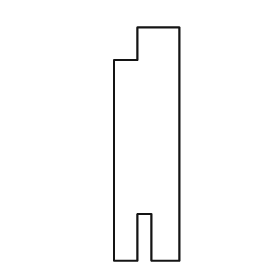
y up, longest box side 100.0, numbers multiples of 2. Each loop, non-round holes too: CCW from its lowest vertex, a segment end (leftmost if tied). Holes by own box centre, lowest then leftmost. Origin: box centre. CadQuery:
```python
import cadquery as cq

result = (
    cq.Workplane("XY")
    .moveTo(-14.0, -50.0)
    .lineTo(-4.0, -50.0)
    .lineTo(-4.0, -30.0)
    .lineTo(2.0, -30.0)
    .lineTo(2.0, -50.0)
    .lineTo(14.0, -50.0)
    .lineTo(14.0, 50.0)
    .lineTo(-4.0, 50.0)
    .lineTo(-4.0, 36.0)
    .lineTo(-14.0, 36.0)
    .close()
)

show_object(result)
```